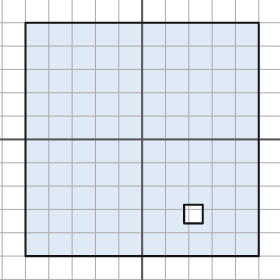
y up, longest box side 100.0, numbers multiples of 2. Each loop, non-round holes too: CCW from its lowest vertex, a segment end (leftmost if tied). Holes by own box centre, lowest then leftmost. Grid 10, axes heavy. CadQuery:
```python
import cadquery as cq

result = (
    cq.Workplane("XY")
    .moveTo(-50.0, -50.0)
    .lineTo(50.0, -50.0)
    .lineTo(50.0, 50.0)
    .lineTo(-50.0, 50.0)
    .close()
    .moveTo(18.0, -36.0)
    .lineTo(26.0, -36.0)
    .lineTo(26.0, -28.0)
    .lineTo(18.0, -28.0)
    .close()
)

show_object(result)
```